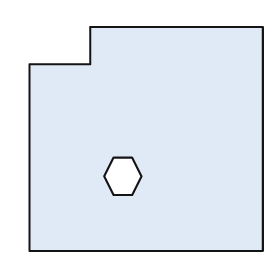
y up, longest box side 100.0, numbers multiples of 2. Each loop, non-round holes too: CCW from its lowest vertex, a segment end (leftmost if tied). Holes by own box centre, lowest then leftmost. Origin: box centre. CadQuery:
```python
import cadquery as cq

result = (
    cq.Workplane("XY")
    .moveTo(-50.0, -48.0)
    .lineTo(50.0, -48.0)
    .lineTo(50.0, 48.0)
    .lineTo(-24.0, 48.0)
    .lineTo(-24.0, 32.0)
    .lineTo(-50.0, 32.0)
    .close()
    .moveTo(-14.0, -24.0)
    .lineTo(-6.0, -24.0)
    .lineTo(-2.0, -16.0)
    .lineTo(-6.0, -8.0)
    .lineTo(-14.0, -8.0)
    .lineTo(-18.0, -16.0)
    .close()
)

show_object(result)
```